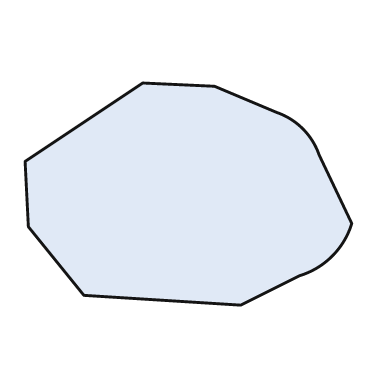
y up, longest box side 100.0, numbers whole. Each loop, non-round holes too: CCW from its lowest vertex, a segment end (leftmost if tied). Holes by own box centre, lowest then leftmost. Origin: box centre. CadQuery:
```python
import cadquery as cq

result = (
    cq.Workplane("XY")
    .moveTo(16.0, -34.0)
    .lineTo(34.0, -25.0)
    .threePointArc((44.0, -19.0), (50.0, -9.0))
    .lineTo(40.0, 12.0)
    .threePointArc((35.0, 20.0), (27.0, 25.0))
    .lineTo(8.0, 33.0)
    .lineTo(-14.0, 34.0)
    .lineTo(-50.0, 10.0)
    .lineTo(-49.0, -10.0)
    .lineTo(-32.0, -31.0)
    .close()
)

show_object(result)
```